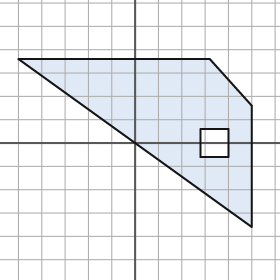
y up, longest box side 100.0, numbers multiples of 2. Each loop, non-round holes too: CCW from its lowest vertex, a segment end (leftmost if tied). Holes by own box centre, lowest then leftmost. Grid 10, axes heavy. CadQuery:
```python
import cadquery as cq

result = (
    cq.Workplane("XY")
    .moveTo(50.0, -36.0)
    .lineTo(50.0, 16.0)
    .lineTo(32.0, 36.0)
    .lineTo(-50.0, 36.0)
    .close()
    .moveTo(28.0, -6.0)
    .lineTo(40.0, -6.0)
    .lineTo(40.0, 6.0)
    .lineTo(28.0, 6.0)
    .close()
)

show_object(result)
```